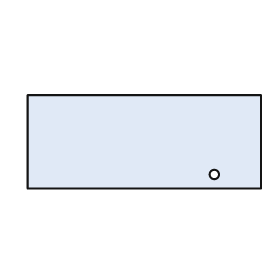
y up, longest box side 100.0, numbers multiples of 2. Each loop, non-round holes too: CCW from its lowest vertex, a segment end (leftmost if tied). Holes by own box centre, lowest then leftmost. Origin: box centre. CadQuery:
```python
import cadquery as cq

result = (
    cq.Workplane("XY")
    .moveTo(-50.0, -20.0)
    .lineTo(50.0, -20.0)
    .lineTo(50.0, 20.0)
    .lineTo(-50.0, 20.0)
    .close()
    .moveTo(30.0, -14.0)
    .circle(2.0)
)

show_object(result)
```